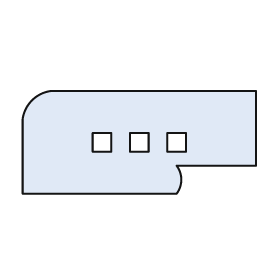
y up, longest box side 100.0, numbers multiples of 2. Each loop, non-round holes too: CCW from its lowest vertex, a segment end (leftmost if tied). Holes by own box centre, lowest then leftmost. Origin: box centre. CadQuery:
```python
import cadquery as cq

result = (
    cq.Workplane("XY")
    .moveTo(-50.0, -22.0)
    .lineTo(16.0, -22.0)
    .threePointArc((18.0, -16.0), (16.0, -10.0))
    .lineTo(50.0, -10.0)
    .lineTo(50.0, 22.0)
    .lineTo(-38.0, 22.0)
    .threePointArc((-46.0, 18.0), (-50.0, 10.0))
    .close()
    .moveTo(-20.0, -4.0)
    .lineTo(-12.0, -4.0)
    .lineTo(-12.0, 4.0)
    .lineTo(-20.0, 4.0)
    .close()
    .moveTo(-4.0, -4.0)
    .lineTo(4.0, -4.0)
    .lineTo(4.0, 4.0)
    .lineTo(-4.0, 4.0)
    .close()
    .moveTo(12.0, -4.0)
    .lineTo(20.0, -4.0)
    .lineTo(20.0, 4.0)
    .lineTo(12.0, 4.0)
    .close()
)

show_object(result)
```